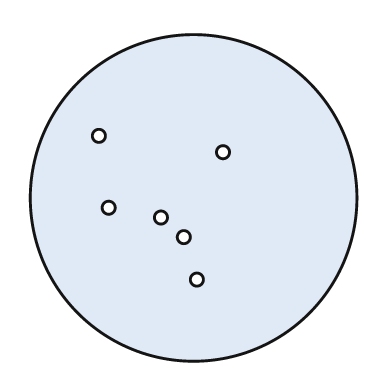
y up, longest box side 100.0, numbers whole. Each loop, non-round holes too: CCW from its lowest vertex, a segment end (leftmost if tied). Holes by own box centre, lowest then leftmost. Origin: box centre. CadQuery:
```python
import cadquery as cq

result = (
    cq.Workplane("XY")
    .moveTo(0.0, 0.0)
    .circle(50.0)
    .moveTo(1.0, -25.0)
    .circle(2.0)
    .moveTo(-3.0, -12.0)
    .circle(2.0)
    .moveTo(-10.0, -6.0)
    .circle(2.0)
    .moveTo(-26.0, -3.0)
    .circle(2.0)
    .moveTo(9.0, 14.0)
    .circle(2.0)
    .moveTo(-29.0, 19.0)
    .circle(2.0)
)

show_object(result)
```